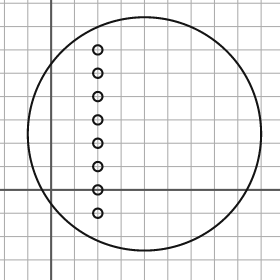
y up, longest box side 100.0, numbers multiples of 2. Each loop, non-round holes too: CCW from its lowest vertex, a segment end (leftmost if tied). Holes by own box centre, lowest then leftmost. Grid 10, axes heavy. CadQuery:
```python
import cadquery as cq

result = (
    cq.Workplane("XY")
    .moveTo(40.0, 24.0)
    .circle(50.0)
    .moveTo(20.0, -10.0)
    .circle(2.0)
    .moveTo(20.0, 0.0)
    .circle(2.0)
    .moveTo(20.0, 10.0)
    .circle(2.0)
    .moveTo(20.0, 20.0)
    .circle(2.0)
    .moveTo(20.0, 30.0)
    .circle(2.0)
    .moveTo(20.0, 40.0)
    .circle(2.0)
    .moveTo(20.0, 50.0)
    .circle(2.0)
    .moveTo(20.0, 60.0)
    .circle(2.0)
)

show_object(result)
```